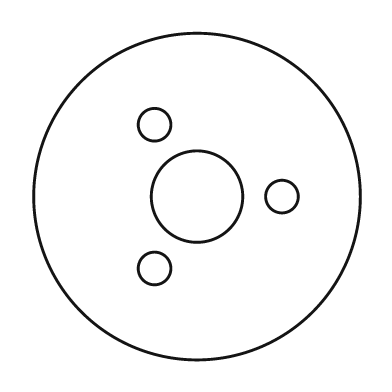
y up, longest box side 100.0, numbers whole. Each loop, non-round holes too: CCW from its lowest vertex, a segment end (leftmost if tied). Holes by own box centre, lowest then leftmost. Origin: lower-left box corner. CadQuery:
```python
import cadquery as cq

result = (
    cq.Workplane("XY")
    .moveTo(50.0, 50.0)
    .circle(50.0)
    .moveTo(37.0, 28.0)
    .circle(5.0)
    .moveTo(50.0, 50.0)
    .circle(14.0)
    .moveTo(76.0, 50.0)
    .circle(5.0)
    .moveTo(37.0, 72.0)
    .circle(5.0)
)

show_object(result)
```